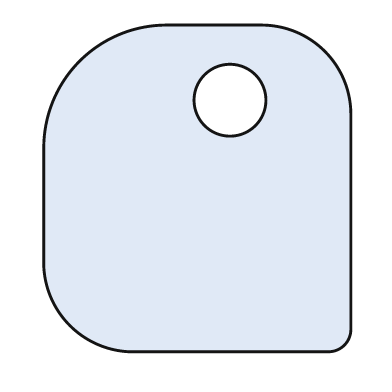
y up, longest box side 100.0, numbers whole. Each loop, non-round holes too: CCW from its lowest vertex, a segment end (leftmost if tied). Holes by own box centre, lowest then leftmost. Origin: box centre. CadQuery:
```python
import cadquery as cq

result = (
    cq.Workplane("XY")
    .moveTo(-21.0, -50.0)
    .lineTo(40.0, -50.0)
    .threePointArc((45.0, -48.0), (47.0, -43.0))
    .lineTo(47.0, 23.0)
    .threePointArc((39.0, 42.0), (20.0, 50.0))
    .lineTo(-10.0, 50.0)
    .threePointArc((-36.0, 39.0), (-47.0, 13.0))
    .lineTo(-47.0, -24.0)
    .threePointArc((-39.0, -42.0), (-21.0, -50.0))
    .close()
    .moveTo(10.0, 27.0)
    .circle(11.0)
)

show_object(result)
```